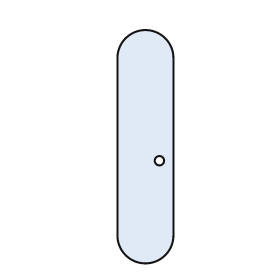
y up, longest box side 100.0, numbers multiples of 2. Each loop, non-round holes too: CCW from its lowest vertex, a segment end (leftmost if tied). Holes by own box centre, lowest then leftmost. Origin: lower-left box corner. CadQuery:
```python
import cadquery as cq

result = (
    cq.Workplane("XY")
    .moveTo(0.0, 12.0)
    .threePointArc((12.0, 0.0), (24.0, 12.0))
    .lineTo(24.0, 88.0)
    .threePointArc((12.0, 100.0), (0.0, 88.0))
    .close()
    .moveTo(18.0, 44.0)
    .circle(2.0)
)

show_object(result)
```